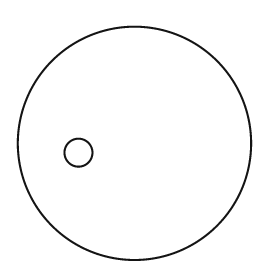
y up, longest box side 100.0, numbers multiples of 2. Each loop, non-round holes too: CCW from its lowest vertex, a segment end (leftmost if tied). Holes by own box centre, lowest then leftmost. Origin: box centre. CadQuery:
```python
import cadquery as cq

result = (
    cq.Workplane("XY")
    .moveTo(0.0, 0.0)
    .circle(50.0)
    .moveTo(-24.0, -4.0)
    .circle(6.0)
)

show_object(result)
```